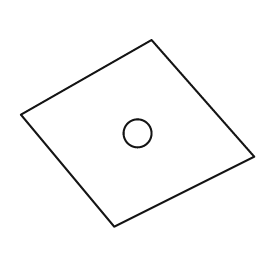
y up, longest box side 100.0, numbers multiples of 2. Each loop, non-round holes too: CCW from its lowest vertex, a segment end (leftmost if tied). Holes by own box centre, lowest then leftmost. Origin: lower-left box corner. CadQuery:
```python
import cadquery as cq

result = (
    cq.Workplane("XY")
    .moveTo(40.0, 0.0)
    .lineTo(100.0, 30.0)
    .lineTo(56.0, 80.0)
    .lineTo(0.0, 48.0)
    .close()
    .moveTo(50.0, 40.0)
    .circle(6.0)
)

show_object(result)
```